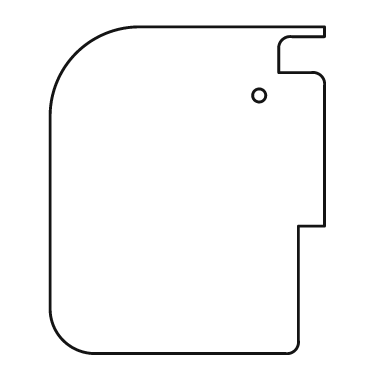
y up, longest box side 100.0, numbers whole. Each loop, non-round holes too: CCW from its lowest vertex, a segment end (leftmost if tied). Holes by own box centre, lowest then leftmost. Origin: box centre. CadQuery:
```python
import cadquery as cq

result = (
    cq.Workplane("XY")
    .moveTo(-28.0, -50.0)
    .lineTo(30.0, -50.0)
    .threePointArc((33.0, -49.0), (34.0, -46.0))
    .lineTo(34.0, -11.0)
    .lineTo(42.0, -11.0)
    .lineTo(42.0, 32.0)
    .threePointArc((41.0, 35.0), (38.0, 36.0))
    .lineTo(28.0, 36.0)
    .lineTo(28.0, 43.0)
    .threePointArc((29.0, 46.0), (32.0, 47.0))
    .lineTo(42.0, 47.0)
    .lineTo(42.0, 50.0)
    .lineTo(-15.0, 50.0)
    .threePointArc((-34.0, 42.0), (-42.0, 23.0))
    .lineTo(-42.0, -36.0)
    .threePointArc((-38.0, -46.0), (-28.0, -50.0))
    .close()
    .moveTo(22.0, 29.0)
    .circle(2.0)
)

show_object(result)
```